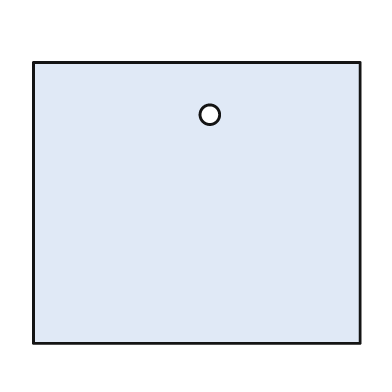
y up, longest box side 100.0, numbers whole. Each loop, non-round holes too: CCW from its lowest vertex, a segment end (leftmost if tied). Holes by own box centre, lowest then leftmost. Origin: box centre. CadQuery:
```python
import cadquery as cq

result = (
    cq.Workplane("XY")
    .moveTo(-50.0, -43.0)
    .lineTo(50.0, -43.0)
    .lineTo(50.0, 43.0)
    .lineTo(-50.0, 43.0)
    .close()
    .moveTo(4.0, 27.0)
    .circle(3.0)
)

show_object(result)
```